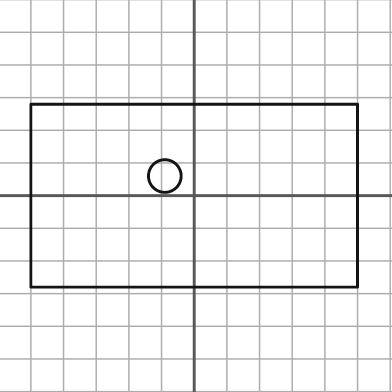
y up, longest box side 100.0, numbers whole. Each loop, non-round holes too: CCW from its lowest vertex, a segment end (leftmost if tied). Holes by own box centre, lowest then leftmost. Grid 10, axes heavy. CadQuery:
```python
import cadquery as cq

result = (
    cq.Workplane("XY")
    .moveTo(-50.0, -28.0)
    .lineTo(50.0, -28.0)
    .lineTo(50.0, 28.0)
    .lineTo(-50.0, 28.0)
    .close()
    .moveTo(-9.0, 6.0)
    .circle(5.0)
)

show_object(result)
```